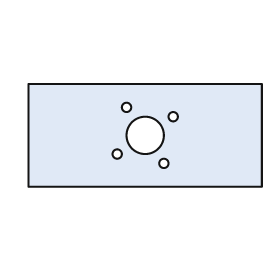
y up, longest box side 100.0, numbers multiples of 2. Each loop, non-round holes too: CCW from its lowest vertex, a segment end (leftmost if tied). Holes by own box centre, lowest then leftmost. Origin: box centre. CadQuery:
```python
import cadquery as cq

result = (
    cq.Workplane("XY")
    .moveTo(-50.0, -22.0)
    .lineTo(50.0, -22.0)
    .lineTo(50.0, 22.0)
    .lineTo(-50.0, 22.0)
    .close()
    .moveTo(8.0, -12.0)
    .circle(2.0)
    .moveTo(-12.0, -8.0)
    .circle(2.0)
    .moveTo(0.0, 0.0)
    .circle(8.0)
    .moveTo(12.0, 8.0)
    .circle(2.0)
    .moveTo(-8.0, 12.0)
    .circle(2.0)
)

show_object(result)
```